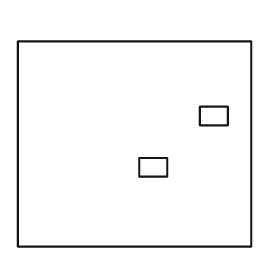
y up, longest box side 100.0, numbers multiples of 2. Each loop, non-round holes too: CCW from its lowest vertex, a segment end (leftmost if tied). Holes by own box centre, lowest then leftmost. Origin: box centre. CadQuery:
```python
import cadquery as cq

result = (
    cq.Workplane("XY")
    .moveTo(-50.0, -44.0)
    .lineTo(50.0, -44.0)
    .lineTo(50.0, 44.0)
    .lineTo(-50.0, 44.0)
    .close()
    .moveTo(2.0, -14.0)
    .lineTo(14.0, -14.0)
    .lineTo(14.0, -6.0)
    .lineTo(2.0, -6.0)
    .close()
    .moveTo(28.0, 8.0)
    .lineTo(40.0, 8.0)
    .lineTo(40.0, 16.0)
    .lineTo(28.0, 16.0)
    .close()
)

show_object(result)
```